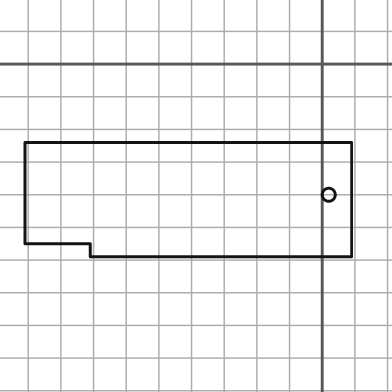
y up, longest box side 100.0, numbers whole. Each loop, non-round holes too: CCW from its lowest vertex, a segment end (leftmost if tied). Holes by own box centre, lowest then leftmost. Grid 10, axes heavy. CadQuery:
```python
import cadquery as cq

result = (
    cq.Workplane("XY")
    .moveTo(-71.0, -59.0)
    .lineTo(9.0, -59.0)
    .lineTo(9.0, -24.0)
    .lineTo(-91.0, -24.0)
    .lineTo(-91.0, -55.0)
    .lineTo(-71.0, -55.0)
    .close()
    .moveTo(2.0, -40.0)
    .circle(2.0)
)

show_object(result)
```